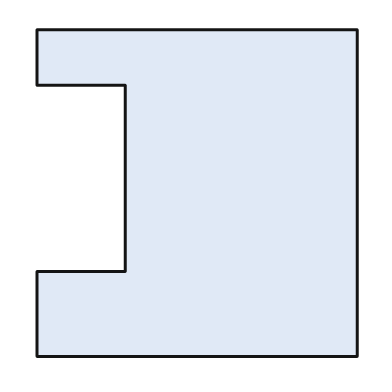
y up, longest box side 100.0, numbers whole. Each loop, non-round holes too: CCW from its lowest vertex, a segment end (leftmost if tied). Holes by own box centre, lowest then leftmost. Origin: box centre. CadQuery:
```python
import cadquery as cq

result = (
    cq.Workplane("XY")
    .moveTo(-49.0, -50.0)
    .lineTo(49.0, -50.0)
    .lineTo(49.0, 50.0)
    .lineTo(-49.0, 50.0)
    .lineTo(-49.0, 33.0)
    .lineTo(-22.0, 33.0)
    .lineTo(-22.0, -24.0)
    .lineTo(-49.0, -24.0)
    .close()
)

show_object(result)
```